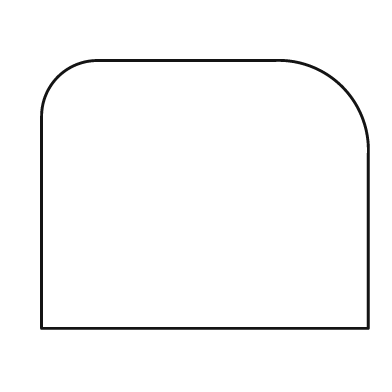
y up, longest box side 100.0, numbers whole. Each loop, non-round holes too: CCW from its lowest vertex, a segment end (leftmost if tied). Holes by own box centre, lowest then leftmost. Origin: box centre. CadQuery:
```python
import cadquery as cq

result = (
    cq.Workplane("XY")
    .moveTo(-50.0, -41.0)
    .lineTo(50.0, -41.0)
    .lineTo(50.0, 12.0)
    .threePointArc((42.0, 33.0), (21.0, 41.0))
    .lineTo(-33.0, 41.0)
    .threePointArc((-45.0, 36.0), (-50.0, 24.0))
    .close()
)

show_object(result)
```